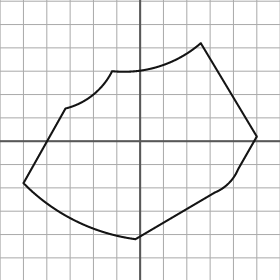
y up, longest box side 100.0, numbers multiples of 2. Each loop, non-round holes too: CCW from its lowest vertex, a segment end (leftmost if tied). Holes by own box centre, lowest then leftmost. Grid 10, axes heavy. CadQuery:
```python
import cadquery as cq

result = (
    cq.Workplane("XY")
    .moveTo(-2.0, -42.0)
    .lineTo(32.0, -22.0)
    .threePointArc((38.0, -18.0), (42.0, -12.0))
    .lineTo(50.0, 2.0)
    .lineTo(26.0, 42.0)
    .threePointArc((8.0, 32.0), (-12.0, 30.0))
    .threePointArc((-20.0, 20.0), (-32.0, 14.0))
    .lineTo(-50.0, -18.0)
    .threePointArc((-28.0, -34.0), (-2.0, -42.0))
    .close()
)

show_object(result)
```